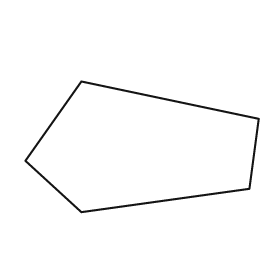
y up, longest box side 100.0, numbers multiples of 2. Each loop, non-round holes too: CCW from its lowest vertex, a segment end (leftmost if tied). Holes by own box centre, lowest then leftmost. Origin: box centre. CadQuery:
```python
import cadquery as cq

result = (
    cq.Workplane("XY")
    .moveTo(-26.0, -28.0)
    .lineTo(46.0, -18.0)
    .lineTo(50.0, 12.0)
    .lineTo(-26.0, 28.0)
    .lineTo(-50.0, -6.0)
    .close()
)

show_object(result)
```